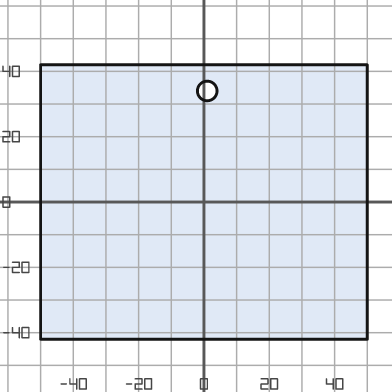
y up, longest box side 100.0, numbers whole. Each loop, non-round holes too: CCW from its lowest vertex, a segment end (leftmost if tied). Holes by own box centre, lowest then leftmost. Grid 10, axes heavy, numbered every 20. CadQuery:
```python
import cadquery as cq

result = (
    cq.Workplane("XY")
    .moveTo(-50.0, -42.0)
    .lineTo(50.0, -42.0)
    .lineTo(50.0, 42.0)
    .lineTo(-50.0, 42.0)
    .close()
    .moveTo(1.0, 34.0)
    .circle(3.0)
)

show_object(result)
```